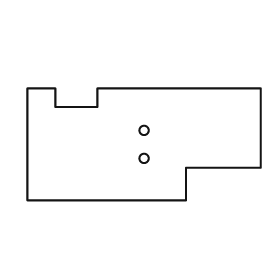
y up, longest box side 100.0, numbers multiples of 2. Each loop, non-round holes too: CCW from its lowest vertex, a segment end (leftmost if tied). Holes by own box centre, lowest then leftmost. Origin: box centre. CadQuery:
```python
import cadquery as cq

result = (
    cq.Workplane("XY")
    .moveTo(-50.0, -24.0)
    .lineTo(18.0, -24.0)
    .lineTo(18.0, -10.0)
    .lineTo(50.0, -10.0)
    .lineTo(50.0, 24.0)
    .lineTo(-20.0, 24.0)
    .lineTo(-20.0, 16.0)
    .lineTo(-38.0, 16.0)
    .lineTo(-38.0, 24.0)
    .lineTo(-50.0, 24.0)
    .close()
    .moveTo(0.0, -6.0)
    .circle(2.0)
    .moveTo(0.0, 6.0)
    .circle(2.0)
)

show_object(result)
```